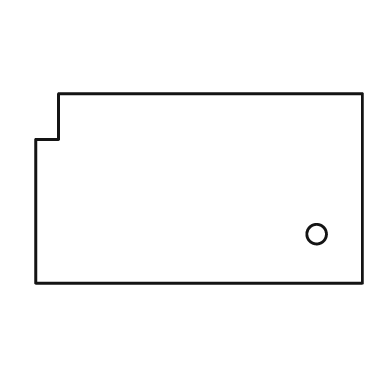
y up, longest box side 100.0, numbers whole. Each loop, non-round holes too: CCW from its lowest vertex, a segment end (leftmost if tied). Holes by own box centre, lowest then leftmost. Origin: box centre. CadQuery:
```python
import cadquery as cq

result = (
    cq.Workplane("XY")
    .moveTo(-50.0, -29.0)
    .lineTo(50.0, -29.0)
    .lineTo(50.0, 29.0)
    .lineTo(-43.0, 29.0)
    .lineTo(-43.0, 15.0)
    .lineTo(-50.0, 15.0)
    .close()
    .moveTo(36.0, -14.0)
    .circle(3.0)
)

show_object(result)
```